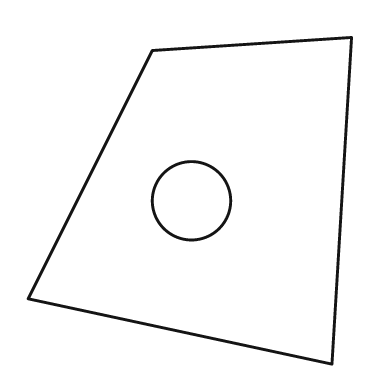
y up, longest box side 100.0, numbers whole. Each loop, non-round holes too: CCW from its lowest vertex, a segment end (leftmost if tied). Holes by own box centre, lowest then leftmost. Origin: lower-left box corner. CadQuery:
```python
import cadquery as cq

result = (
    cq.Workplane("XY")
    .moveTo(93.0, 0.0)
    .lineTo(99.0, 100.0)
    .lineTo(38.0, 96.0)
    .lineTo(0.0, 20.0)
    .close()
    .moveTo(50.0, 50.0)
    .circle(12.0)
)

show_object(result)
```